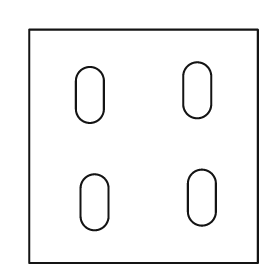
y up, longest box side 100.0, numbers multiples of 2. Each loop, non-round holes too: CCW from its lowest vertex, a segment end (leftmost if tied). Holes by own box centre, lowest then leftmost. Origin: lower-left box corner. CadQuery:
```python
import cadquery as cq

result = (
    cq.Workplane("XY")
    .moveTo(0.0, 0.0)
    .lineTo(98.0, 0.0)
    .lineTo(98.0, 100.0)
    .lineTo(0.0, 100.0)
    .close()
    .moveTo(22.0, 20.0)
    .threePointArc((28.0, 14.0), (34.0, 20.0))
    .lineTo(34.0, 32.0)
    .threePointArc((28.0, 38.0), (22.0, 32.0))
    .close()
    .moveTo(68.0, 22.0)
    .threePointArc((74.0, 16.0), (80.0, 22.0))
    .lineTo(80.0, 34.0)
    .threePointArc((74.0, 40.0), (68.0, 34.0))
    .close()
    .moveTo(20.0, 66.0)
    .threePointArc((26.0, 60.0), (32.0, 66.0))
    .lineTo(32.0, 78.0)
    .threePointArc((26.0, 84.0), (20.0, 78.0))
    .close()
    .moveTo(66.0, 68.0)
    .threePointArc((72.0, 62.0), (78.0, 68.0))
    .lineTo(78.0, 80.0)
    .threePointArc((72.0, 86.0), (66.0, 80.0))
    .close()
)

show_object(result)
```